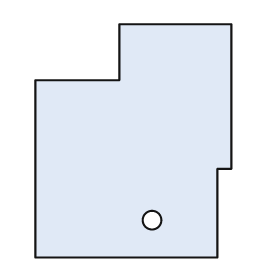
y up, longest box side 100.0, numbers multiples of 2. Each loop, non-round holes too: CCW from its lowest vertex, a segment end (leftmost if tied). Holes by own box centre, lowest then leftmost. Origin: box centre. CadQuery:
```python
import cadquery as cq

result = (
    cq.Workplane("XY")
    .moveTo(-42.0, -50.0)
    .lineTo(36.0, -50.0)
    .lineTo(36.0, -12.0)
    .lineTo(42.0, -12.0)
    .lineTo(42.0, 50.0)
    .lineTo(-6.0, 50.0)
    .lineTo(-6.0, 26.0)
    .lineTo(-42.0, 26.0)
    .close()
    .moveTo(8.0, -34.0)
    .circle(4.0)
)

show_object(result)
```